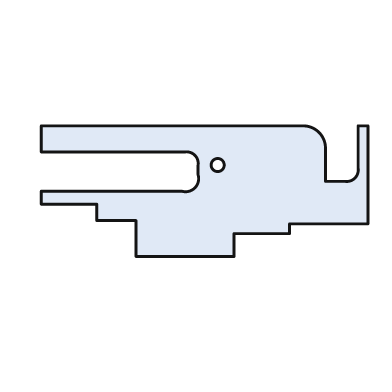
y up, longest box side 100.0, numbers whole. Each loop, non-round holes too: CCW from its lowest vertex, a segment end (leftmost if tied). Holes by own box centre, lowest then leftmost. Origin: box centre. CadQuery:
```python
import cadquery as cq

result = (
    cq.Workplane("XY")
    .moveTo(-21.0, -20.0)
    .lineTo(9.0, -20.0)
    .lineTo(9.0, -13.0)
    .lineTo(26.0, -13.0)
    .lineTo(26.0, -10.0)
    .lineTo(50.0, -10.0)
    .lineTo(50.0, 20.0)
    .lineTo(47.0, 20.0)
    .lineTo(47.0, 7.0)
    .threePointArc((46.0, 4.0), (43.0, 3.0))
    .lineTo(37.0, 3.0)
    .lineTo(37.0, 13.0)
    .threePointArc((35.0, 18.0), (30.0, 20.0))
    .lineTo(-50.0, 20.0)
    .lineTo(-50.0, 12.0)
    .lineTo(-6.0, 12.0)
    .threePointArc((-3.0, 11.0), (-2.0, 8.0))
    .lineTo(-2.0, 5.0)
    .threePointArc((-3.0, 1.0), (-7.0, 0.0))
    .lineTo(-50.0, 0.0)
    .lineTo(-50.0, -4.0)
    .lineTo(-33.0, -4.0)
    .lineTo(-33.0, -9.0)
    .lineTo(-21.0, -9.0)
    .close()
    .moveTo(4.0, 8.0)
    .circle(2.0)
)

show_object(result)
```